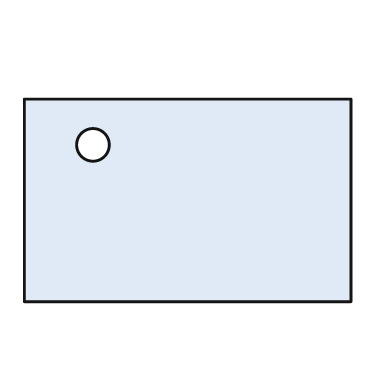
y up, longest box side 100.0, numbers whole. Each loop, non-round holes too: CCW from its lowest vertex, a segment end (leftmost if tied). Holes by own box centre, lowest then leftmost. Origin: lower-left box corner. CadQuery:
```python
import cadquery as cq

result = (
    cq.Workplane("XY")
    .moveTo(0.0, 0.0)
    .lineTo(100.0, 0.0)
    .lineTo(100.0, 62.0)
    .lineTo(0.0, 62.0)
    .close()
    .moveTo(21.0, 48.0)
    .circle(5.0)
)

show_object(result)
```